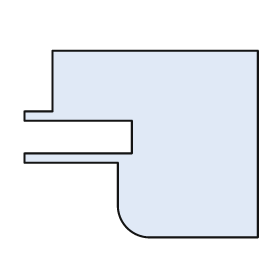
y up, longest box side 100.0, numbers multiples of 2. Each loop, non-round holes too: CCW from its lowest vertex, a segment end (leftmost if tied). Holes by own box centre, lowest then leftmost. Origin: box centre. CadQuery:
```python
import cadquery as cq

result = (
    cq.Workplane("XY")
    .moveTo(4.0, -40.0)
    .lineTo(50.0, -40.0)
    .lineTo(50.0, 40.0)
    .lineTo(-38.0, 40.0)
    .lineTo(-38.0, 14.0)
    .lineTo(-50.0, 14.0)
    .lineTo(-50.0, 10.0)
    .lineTo(-4.0, 10.0)
    .lineTo(-4.0, -4.0)
    .lineTo(-50.0, -4.0)
    .lineTo(-50.0, -8.0)
    .lineTo(-10.0, -8.0)
    .lineTo(-10.0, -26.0)
    .threePointArc((-6.0, -36.0), (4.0, -40.0))
    .close()
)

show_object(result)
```